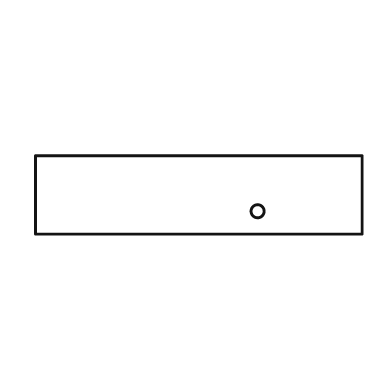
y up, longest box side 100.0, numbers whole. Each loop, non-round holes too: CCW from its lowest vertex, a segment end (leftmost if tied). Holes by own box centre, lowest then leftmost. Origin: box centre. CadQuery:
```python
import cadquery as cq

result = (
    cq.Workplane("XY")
    .moveTo(-50.0, -12.0)
    .lineTo(50.0, -12.0)
    .lineTo(50.0, 12.0)
    .lineTo(-50.0, 12.0)
    .close()
    .moveTo(18.0, -5.0)
    .circle(2.0)
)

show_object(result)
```